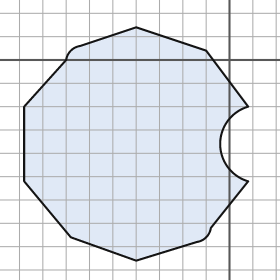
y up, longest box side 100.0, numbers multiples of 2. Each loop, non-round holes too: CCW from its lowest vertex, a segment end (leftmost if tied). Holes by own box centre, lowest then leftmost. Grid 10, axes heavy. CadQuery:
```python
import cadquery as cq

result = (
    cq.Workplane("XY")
    .moveTo(-40.0, -86.0)
    .lineTo(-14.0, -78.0)
    .threePointArc((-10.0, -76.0), (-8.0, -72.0))
    .lineTo(8.0, -52.0)
    .threePointArc((-4.0, -36.0), (8.0, -20.0))
    .lineTo(-10.0, 4.0)
    .lineTo(-40.0, 14.0)
    .lineTo(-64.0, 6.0)
    .threePointArc((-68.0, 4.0), (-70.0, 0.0))
    .lineTo(-88.0, -20.0)
    .lineTo(-88.0, -52.0)
    .lineTo(-68.0, -76.0)
    .close()
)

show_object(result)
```